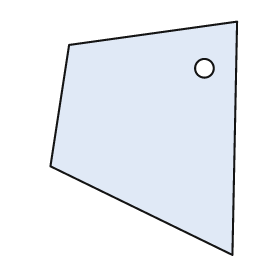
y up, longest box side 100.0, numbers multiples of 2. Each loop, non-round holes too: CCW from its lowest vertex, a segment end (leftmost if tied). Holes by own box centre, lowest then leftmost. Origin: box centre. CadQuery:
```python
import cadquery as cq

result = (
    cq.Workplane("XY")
    .moveTo(38.0, -50.0)
    .lineTo(40.0, 50.0)
    .lineTo(-32.0, 40.0)
    .lineTo(-40.0, -12.0)
    .close()
    .moveTo(26.0, 30.0)
    .circle(4.0)
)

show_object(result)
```